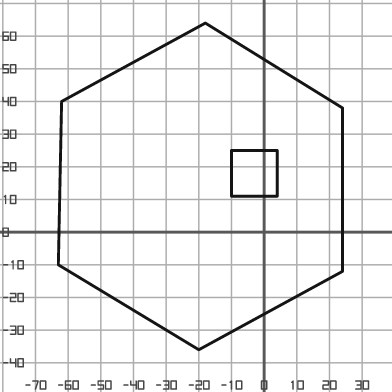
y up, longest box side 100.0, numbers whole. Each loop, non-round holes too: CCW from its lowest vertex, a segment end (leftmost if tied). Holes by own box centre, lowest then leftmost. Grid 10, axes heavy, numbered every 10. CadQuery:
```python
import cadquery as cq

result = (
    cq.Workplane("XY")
    .moveTo(-20.0, -36.0)
    .lineTo(24.0, -12.0)
    .lineTo(24.0, 38.0)
    .lineTo(-18.0, 64.0)
    .lineTo(-62.0, 40.0)
    .lineTo(-63.0, -10.0)
    .close()
    .moveTo(-10.0, 11.0)
    .lineTo(4.0, 11.0)
    .lineTo(4.0, 25.0)
    .lineTo(-10.0, 25.0)
    .close()
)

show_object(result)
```